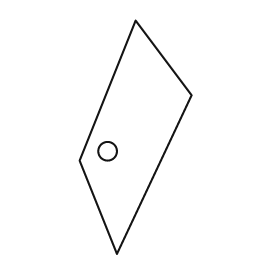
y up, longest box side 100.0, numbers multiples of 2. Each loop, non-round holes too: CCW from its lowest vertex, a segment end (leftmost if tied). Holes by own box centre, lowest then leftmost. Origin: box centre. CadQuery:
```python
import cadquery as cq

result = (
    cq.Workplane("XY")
    .moveTo(-8.0, -50.0)
    .lineTo(24.0, 18.0)
    .lineTo(0.0, 50.0)
    .lineTo(-24.0, -10.0)
    .close()
    .moveTo(-12.0, -6.0)
    .circle(4.0)
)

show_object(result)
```